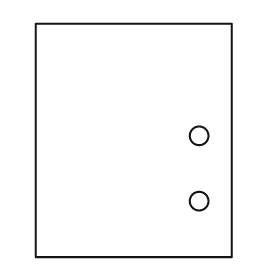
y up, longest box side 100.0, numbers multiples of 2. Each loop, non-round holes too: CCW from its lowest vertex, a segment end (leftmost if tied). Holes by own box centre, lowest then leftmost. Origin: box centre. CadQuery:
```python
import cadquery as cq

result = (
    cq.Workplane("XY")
    .moveTo(-42.0, -50.0)
    .lineTo(42.0, -50.0)
    .lineTo(42.0, 50.0)
    .lineTo(-42.0, 50.0)
    .close()
    .moveTo(28.0, -26.0)
    .circle(4.0)
    .moveTo(28.0, 2.0)
    .circle(4.0)
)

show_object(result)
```